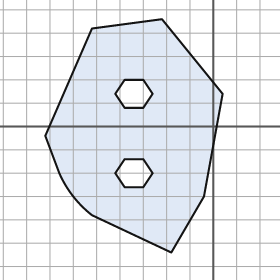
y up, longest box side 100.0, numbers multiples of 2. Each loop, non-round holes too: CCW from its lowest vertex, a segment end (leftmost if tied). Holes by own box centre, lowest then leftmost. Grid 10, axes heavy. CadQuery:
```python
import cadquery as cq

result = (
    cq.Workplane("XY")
    .moveTo(-18.0, -54.0)
    .lineTo(-4.0, -30.0)
    .lineTo(4.0, 14.0)
    .lineTo(-22.0, 46.0)
    .lineTo(-52.0, 42.0)
    .lineTo(-72.0, -4.0)
    .lineTo(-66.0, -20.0)
    .threePointArc((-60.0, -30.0), (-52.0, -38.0))
    .close()
    .moveTo(-38.0, -26.0)
    .lineTo(-30.0, -26.0)
    .lineTo(-26.0, -20.0)
    .lineTo(-30.0, -14.0)
    .lineTo(-38.0, -14.0)
    .lineTo(-42.0, -20.0)
    .close()
    .moveTo(-38.0, 8.0)
    .lineTo(-30.0, 8.0)
    .lineTo(-26.0, 14.0)
    .lineTo(-30.0, 20.0)
    .lineTo(-38.0, 20.0)
    .lineTo(-42.0, 14.0)
    .close()
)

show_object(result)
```